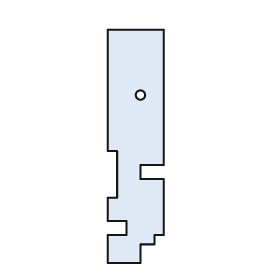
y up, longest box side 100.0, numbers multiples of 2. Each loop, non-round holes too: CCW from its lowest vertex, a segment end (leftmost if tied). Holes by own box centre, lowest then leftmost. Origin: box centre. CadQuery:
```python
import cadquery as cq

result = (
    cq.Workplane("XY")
    .moveTo(-12.0, -50.0)
    .lineTo(2.0, -50.0)
    .lineTo(2.0, -42.0)
    .lineTo(8.0, -42.0)
    .lineTo(8.0, -38.0)
    .lineTo(12.0, -38.0)
    .lineTo(12.0, -14.0)
    .lineTo(2.0, -14.0)
    .lineTo(2.0, -8.0)
    .lineTo(12.0, -8.0)
    .lineTo(12.0, 50.0)
    .lineTo(-12.0, 50.0)
    .lineTo(-12.0, -2.0)
    .lineTo(-8.0, -2.0)
    .lineTo(-8.0, -22.0)
    .lineTo(-12.0, -22.0)
    .lineTo(-12.0, -32.0)
    .lineTo(-4.0, -32.0)
    .lineTo(-4.0, -38.0)
    .lineTo(-12.0, -38.0)
    .close()
    .moveTo(2.0, 22.0)
    .circle(2.0)
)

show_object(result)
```